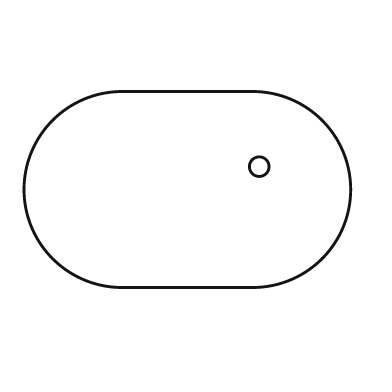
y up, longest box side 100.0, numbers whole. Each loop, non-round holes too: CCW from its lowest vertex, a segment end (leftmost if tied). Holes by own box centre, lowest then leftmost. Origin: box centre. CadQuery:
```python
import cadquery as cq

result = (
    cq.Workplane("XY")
    .moveTo(-20.0, -30.0)
    .lineTo(20.0, -30.0)
    .threePointArc((50.0, 0.0), (20.0, 30.0))
    .lineTo(-20.0, 30.0)
    .threePointArc((-50.0, 0.0), (-20.0, -30.0))
    .close()
    .moveTo(22.0, 7.0)
    .circle(3.0)
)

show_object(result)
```